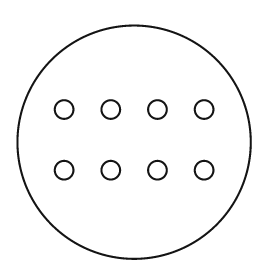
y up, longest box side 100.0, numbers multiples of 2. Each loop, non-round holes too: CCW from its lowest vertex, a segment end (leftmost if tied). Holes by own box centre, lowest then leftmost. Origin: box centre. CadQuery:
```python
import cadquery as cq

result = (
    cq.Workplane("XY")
    .moveTo(0.0, 0.0)
    .circle(50.0)
    .moveTo(-30.0, -12.0)
    .circle(4.0)
    .moveTo(-10.0, -12.0)
    .circle(4.0)
    .moveTo(10.0, -12.0)
    .circle(4.0)
    .moveTo(30.0, -12.0)
    .circle(4.0)
    .moveTo(-30.0, 14.0)
    .circle(4.0)
    .moveTo(-10.0, 14.0)
    .circle(4.0)
    .moveTo(10.0, 14.0)
    .circle(4.0)
    .moveTo(30.0, 14.0)
    .circle(4.0)
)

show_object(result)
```